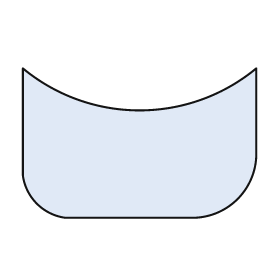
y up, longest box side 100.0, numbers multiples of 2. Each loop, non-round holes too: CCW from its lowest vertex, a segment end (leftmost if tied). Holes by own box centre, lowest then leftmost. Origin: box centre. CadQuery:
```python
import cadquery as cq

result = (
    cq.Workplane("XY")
    .moveTo(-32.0, -32.0)
    .lineTo(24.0, -32.0)
    .threePointArc((42.0, -24.0), (50.0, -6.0))
    .lineTo(50.0, 32.0)
    .threePointArc((0.0, 14.0), (-50.0, 32.0))
    .lineTo(-50.0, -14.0)
    .threePointArc((-44.0, -26.0), (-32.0, -32.0))
    .close()
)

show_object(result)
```